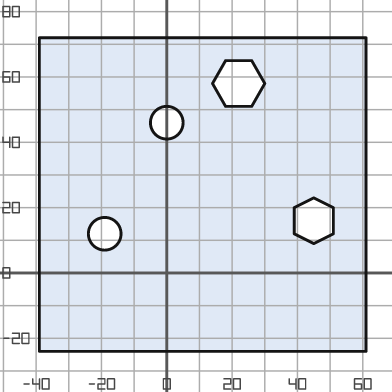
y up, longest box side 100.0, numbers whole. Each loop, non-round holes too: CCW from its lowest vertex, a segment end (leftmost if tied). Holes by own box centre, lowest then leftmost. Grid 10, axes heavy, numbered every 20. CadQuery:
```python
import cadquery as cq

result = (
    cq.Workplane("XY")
    .moveTo(-39.0, -24.0)
    .lineTo(61.0, -24.0)
    .lineTo(61.0, 72.0)
    .lineTo(-39.0, 72.0)
    .close()
    .moveTo(-19.0, 12.0)
    .circle(5.0)
    .moveTo(45.0, 9.0)
    .lineTo(51.0, 12.0)
    .lineTo(51.0, 20.0)
    .lineTo(45.0, 23.0)
    .lineTo(39.0, 20.0)
    .lineTo(39.0, 12.0)
    .close()
    .moveTo(0.0, 46.0)
    .circle(5.0)
    .moveTo(18.0, 51.0)
    .lineTo(26.0, 51.0)
    .lineTo(30.0, 58.0)
    .lineTo(26.0, 65.0)
    .lineTo(18.0, 65.0)
    .lineTo(14.0, 58.0)
    .close()
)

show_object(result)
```